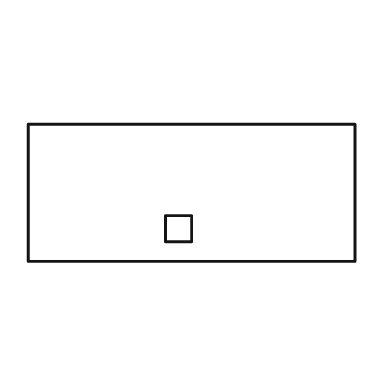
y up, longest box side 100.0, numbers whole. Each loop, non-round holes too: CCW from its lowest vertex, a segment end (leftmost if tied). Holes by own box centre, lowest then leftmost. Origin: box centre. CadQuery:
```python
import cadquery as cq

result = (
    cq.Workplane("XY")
    .moveTo(-50.0, -21.0)
    .lineTo(50.0, -21.0)
    .lineTo(50.0, 21.0)
    .lineTo(-50.0, 21.0)
    .close()
    .moveTo(-8.0, -15.0)
    .lineTo(0.0, -15.0)
    .lineTo(0.0, -7.0)
    .lineTo(-8.0, -7.0)
    .close()
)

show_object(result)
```